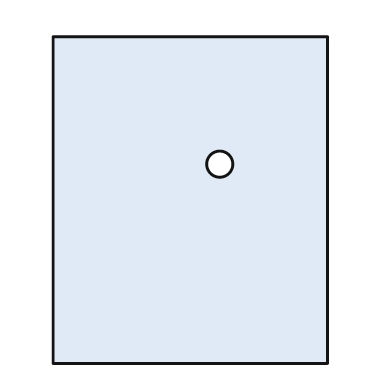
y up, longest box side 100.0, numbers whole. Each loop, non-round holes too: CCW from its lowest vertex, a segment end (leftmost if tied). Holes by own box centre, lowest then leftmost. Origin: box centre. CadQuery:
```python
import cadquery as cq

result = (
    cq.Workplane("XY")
    .moveTo(-42.0, -50.0)
    .lineTo(42.0, -50.0)
    .lineTo(42.0, 50.0)
    .lineTo(-42.0, 50.0)
    .close()
    .moveTo(9.0, 11.0)
    .circle(4.0)
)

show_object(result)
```